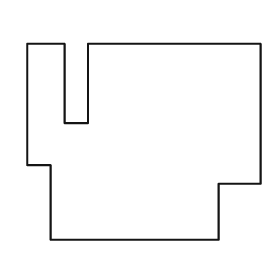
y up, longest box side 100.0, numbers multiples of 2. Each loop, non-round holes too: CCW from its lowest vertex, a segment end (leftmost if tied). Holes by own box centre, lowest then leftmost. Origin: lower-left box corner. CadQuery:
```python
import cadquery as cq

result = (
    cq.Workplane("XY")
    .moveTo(10.0, 0.0)
    .lineTo(82.0, 0.0)
    .lineTo(82.0, 24.0)
    .lineTo(100.0, 24.0)
    .lineTo(100.0, 84.0)
    .lineTo(26.0, 84.0)
    .lineTo(26.0, 50.0)
    .lineTo(16.0, 50.0)
    .lineTo(16.0, 84.0)
    .lineTo(0.0, 84.0)
    .lineTo(0.0, 32.0)
    .lineTo(10.0, 32.0)
    .close()
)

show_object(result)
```